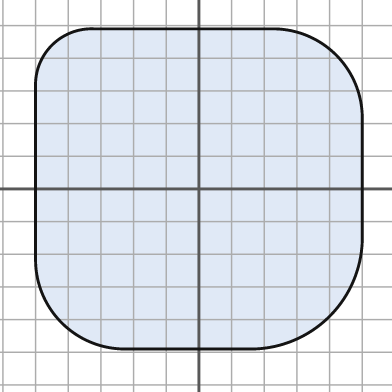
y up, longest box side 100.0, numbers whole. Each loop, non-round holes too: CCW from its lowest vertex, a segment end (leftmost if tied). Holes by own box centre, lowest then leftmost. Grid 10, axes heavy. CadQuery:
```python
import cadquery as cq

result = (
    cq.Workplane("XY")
    .moveTo(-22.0, -49.0)
    .lineTo(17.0, -49.0)
    .threePointArc((40.0, -39.0), (50.0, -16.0))
    .lineTo(50.0, 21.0)
    .threePointArc((42.0, 41.0), (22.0, 49.0))
    .lineTo(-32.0, 49.0)
    .threePointArc((-45.0, 44.0), (-50.0, 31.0))
    .lineTo(-50.0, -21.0)
    .threePointArc((-42.0, -41.0), (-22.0, -49.0))
    .close()
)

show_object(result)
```